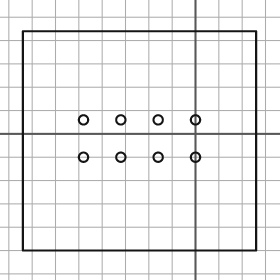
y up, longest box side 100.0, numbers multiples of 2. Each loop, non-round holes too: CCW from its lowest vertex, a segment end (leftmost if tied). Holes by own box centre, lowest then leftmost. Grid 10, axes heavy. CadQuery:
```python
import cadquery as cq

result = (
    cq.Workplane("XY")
    .moveTo(-74.0, -50.0)
    .lineTo(26.0, -50.0)
    .lineTo(26.0, 44.0)
    .lineTo(-74.0, 44.0)
    .close()
    .moveTo(-48.0, -10.0)
    .circle(2.0)
    .moveTo(-32.0, -10.0)
    .circle(2.0)
    .moveTo(-16.0, -10.0)
    .circle(2.0)
    .moveTo(0.0, -10.0)
    .circle(2.0)
    .moveTo(-48.0, 6.0)
    .circle(2.0)
    .moveTo(-32.0, 6.0)
    .circle(2.0)
    .moveTo(-16.0, 6.0)
    .circle(2.0)
    .moveTo(0.0, 6.0)
    .circle(2.0)
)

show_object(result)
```